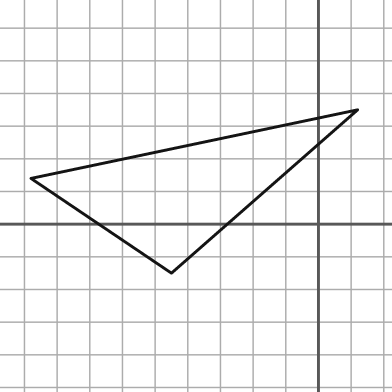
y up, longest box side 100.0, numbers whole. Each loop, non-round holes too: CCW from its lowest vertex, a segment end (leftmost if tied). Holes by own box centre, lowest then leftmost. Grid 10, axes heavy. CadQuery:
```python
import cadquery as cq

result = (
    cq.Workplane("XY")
    .moveTo(-45.0, -15.0)
    .lineTo(12.0, 35.0)
    .lineTo(-88.0, 14.0)
    .close()
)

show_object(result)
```